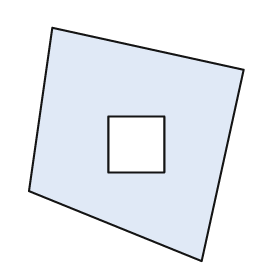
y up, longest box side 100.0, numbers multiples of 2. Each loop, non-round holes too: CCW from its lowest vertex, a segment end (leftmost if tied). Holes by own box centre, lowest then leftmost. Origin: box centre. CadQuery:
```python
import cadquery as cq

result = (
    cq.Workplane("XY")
    .moveTo(28.0, -50.0)
    .lineTo(46.0, 32.0)
    .lineTo(-36.0, 50.0)
    .lineTo(-46.0, -20.0)
    .close()
    .moveTo(-12.0, -12.0)
    .lineTo(12.0, -12.0)
    .lineTo(12.0, 12.0)
    .lineTo(-12.0, 12.0)
    .close()
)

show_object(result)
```